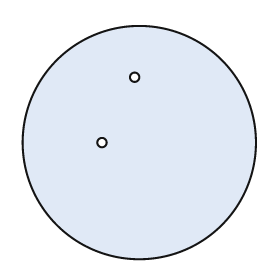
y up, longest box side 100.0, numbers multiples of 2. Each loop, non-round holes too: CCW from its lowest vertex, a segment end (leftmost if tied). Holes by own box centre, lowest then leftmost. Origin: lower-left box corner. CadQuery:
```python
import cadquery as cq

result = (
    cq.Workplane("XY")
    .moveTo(50.0, 50.0)
    .circle(50.0)
    .moveTo(34.0, 50.0)
    .circle(2.0)
    .moveTo(48.0, 78.0)
    .circle(2.0)
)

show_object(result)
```